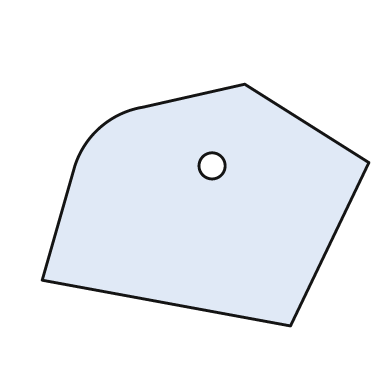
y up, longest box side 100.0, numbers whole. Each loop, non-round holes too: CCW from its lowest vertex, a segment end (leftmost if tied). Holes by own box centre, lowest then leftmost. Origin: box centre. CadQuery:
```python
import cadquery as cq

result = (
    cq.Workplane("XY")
    .moveTo(26.0, -37.0)
    .lineTo(50.0, 13.0)
    .lineTo(12.0, 37.0)
    .lineTo(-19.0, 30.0)
    .threePointArc((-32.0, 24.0), (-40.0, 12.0))
    .lineTo(-50.0, -23.0)
    .close()
    .moveTo(2.0, 12.0)
    .circle(4.0)
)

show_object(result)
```